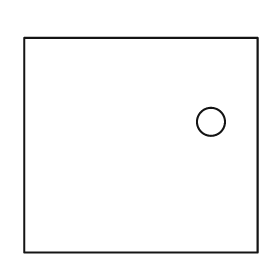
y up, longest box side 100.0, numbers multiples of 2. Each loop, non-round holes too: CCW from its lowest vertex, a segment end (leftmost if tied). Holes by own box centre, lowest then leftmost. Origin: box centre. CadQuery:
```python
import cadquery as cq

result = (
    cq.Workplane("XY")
    .moveTo(-50.0, -46.0)
    .lineTo(50.0, -46.0)
    .lineTo(50.0, 46.0)
    .lineTo(-50.0, 46.0)
    .close()
    .moveTo(30.0, 10.0)
    .circle(6.0)
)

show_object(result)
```